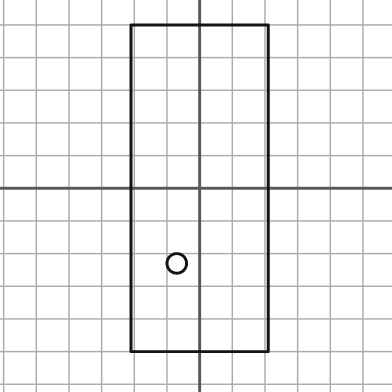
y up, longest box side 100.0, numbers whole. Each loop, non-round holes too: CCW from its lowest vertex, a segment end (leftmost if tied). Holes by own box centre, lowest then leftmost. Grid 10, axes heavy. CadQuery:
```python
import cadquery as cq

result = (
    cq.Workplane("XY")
    .moveTo(-21.0, -50.0)
    .lineTo(21.0, -50.0)
    .lineTo(21.0, 50.0)
    .lineTo(-21.0, 50.0)
    .close()
    .moveTo(-7.0, -23.0)
    .circle(3.0)
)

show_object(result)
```